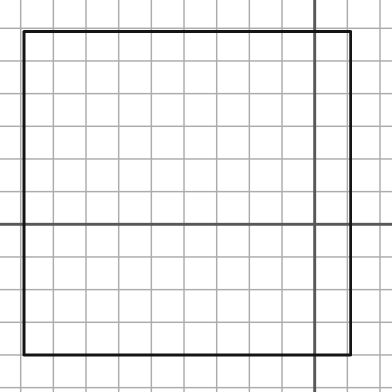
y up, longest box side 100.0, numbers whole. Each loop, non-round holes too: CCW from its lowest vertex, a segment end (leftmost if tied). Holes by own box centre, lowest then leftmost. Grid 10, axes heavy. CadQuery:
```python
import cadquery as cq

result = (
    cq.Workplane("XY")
    .moveTo(-89.0, -40.0)
    .lineTo(11.0, -40.0)
    .lineTo(11.0, 59.0)
    .lineTo(-89.0, 59.0)
    .close()
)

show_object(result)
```